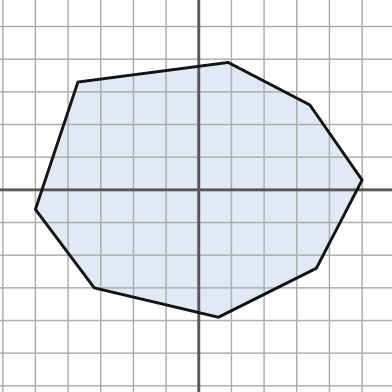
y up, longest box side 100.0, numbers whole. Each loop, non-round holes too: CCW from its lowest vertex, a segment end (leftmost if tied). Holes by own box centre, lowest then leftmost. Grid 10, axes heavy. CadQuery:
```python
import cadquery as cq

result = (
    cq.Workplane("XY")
    .moveTo(6.0, -39.0)
    .lineTo(36.0, -24.0)
    .lineTo(50.0, 3.0)
    .lineTo(34.0, 26.0)
    .lineTo(9.0, 39.0)
    .lineTo(-37.0, 33.0)
    .lineTo(-50.0, -6.0)
    .lineTo(-32.0, -30.0)
    .close()
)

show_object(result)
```